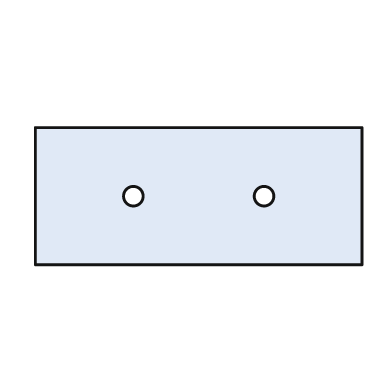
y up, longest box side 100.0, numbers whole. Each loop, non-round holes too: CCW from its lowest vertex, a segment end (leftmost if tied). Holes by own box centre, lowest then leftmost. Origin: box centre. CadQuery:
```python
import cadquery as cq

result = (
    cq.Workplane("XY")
    .moveTo(-50.0, -21.0)
    .lineTo(50.0, -21.0)
    .lineTo(50.0, 21.0)
    .lineTo(-50.0, 21.0)
    .close()
    .moveTo(-20.0, 0.0)
    .circle(3.0)
    .moveTo(20.0, 0.0)
    .circle(3.0)
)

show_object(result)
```